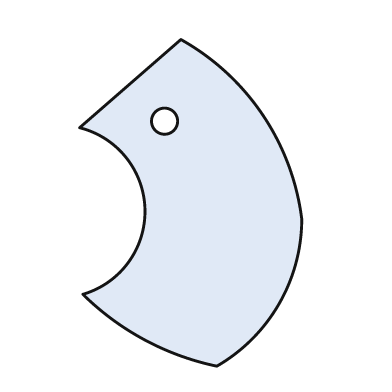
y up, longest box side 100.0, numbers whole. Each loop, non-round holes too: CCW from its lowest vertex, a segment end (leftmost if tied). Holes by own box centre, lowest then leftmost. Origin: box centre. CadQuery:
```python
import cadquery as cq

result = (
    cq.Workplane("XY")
    .moveTo(8.0, -50.0)
    .threePointArc((27.0, -31.0), (34.0, -5.0))
    .threePointArc((22.0, 27.0), (-3.0, 50.0))
    .lineTo(-34.0, 23.0)
    .threePointArc((-14.0, -2.0), (-33.0, -28.0))
    .threePointArc((-14.0, -42.0), (8.0, -50.0))
    .close()
    .moveTo(-8.0, 25.0)
    .circle(4.0)
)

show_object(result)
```